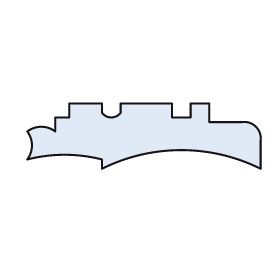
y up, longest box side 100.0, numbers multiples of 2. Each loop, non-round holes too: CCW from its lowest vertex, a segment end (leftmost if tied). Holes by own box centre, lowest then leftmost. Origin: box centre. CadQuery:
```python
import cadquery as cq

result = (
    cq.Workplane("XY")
    .moveTo(-18.0, -14.0)
    .threePointArc((16.0, -6.0), (50.0, -14.0))
    .lineTo(50.0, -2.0)
    .threePointArc((48.0, 4.0), (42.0, 6.0))
    .lineTo(28.0, 6.0)
    .lineTo(28.0, 14.0)
    .lineTo(20.0, 14.0)
    .lineTo(20.0, 8.0)
    .lineTo(12.0, 8.0)
    .lineTo(12.0, 14.0)
    .lineTo(-10.0, 14.0)
    .lineTo(-10.0, 10.0)
    .threePointArc((-14.0, 8.0), (-18.0, 10.0))
    .lineTo(-18.0, 14.0)
    .lineTo(-32.0, 14.0)
    .lineTo(-32.0, 8.0)
    .lineTo(-38.0, 8.0)
    .lineTo(-38.0, 2.0)
    .threePointArc((-44.0, 4.0), (-50.0, 2.0))
    .threePointArc((-48.0, -4.0), (-50.0, -10.0))
    .threePointArc((-34.0, -8.0), (-18.0, -10.0))
    .close()
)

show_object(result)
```